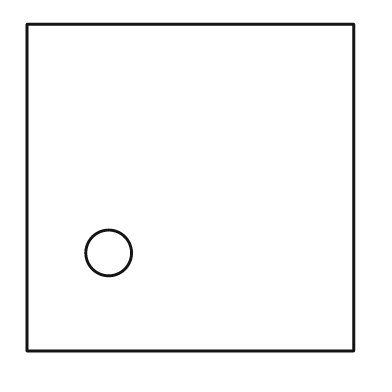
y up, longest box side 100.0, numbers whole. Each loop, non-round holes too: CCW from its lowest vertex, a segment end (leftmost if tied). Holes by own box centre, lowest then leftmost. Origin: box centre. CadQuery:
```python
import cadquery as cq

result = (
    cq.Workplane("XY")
    .moveTo(-50.0, -50.0)
    .lineTo(50.0, -50.0)
    .lineTo(50.0, 50.0)
    .lineTo(-50.0, 50.0)
    .close()
    .moveTo(-25.0, -20.0)
    .circle(7.0)
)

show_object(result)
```